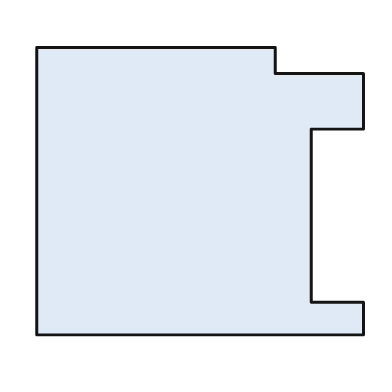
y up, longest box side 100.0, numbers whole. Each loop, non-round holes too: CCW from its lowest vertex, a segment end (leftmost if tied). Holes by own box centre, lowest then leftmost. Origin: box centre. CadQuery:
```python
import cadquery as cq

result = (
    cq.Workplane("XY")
    .moveTo(-50.0, -44.0)
    .lineTo(50.0, -44.0)
    .lineTo(50.0, -34.0)
    .lineTo(34.0, -34.0)
    .lineTo(34.0, 19.0)
    .lineTo(50.0, 19.0)
    .lineTo(50.0, 36.0)
    .lineTo(23.0, 36.0)
    .lineTo(23.0, 44.0)
    .lineTo(-50.0, 44.0)
    .close()
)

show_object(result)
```